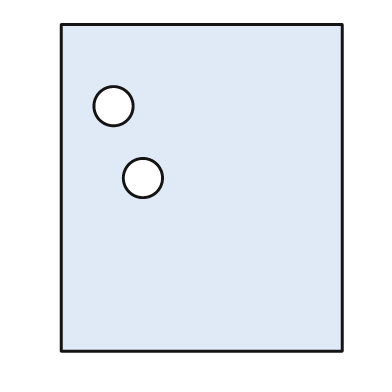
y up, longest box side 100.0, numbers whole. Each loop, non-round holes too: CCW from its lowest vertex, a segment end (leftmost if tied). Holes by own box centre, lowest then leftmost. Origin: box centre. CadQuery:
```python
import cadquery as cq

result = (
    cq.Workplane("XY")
    .moveTo(-43.0, -50.0)
    .lineTo(43.0, -50.0)
    .lineTo(43.0, 50.0)
    .lineTo(-43.0, 50.0)
    .close()
    .moveTo(-18.0, 3.0)
    .circle(6.0)
    .moveTo(-27.0, 25.0)
    .circle(6.0)
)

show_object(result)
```